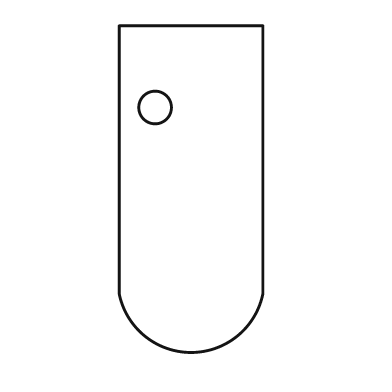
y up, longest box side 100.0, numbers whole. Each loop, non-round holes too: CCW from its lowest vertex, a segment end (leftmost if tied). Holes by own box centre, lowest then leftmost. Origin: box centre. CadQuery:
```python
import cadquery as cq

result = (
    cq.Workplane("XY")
    .moveTo(-22.0, -32.0)
    .threePointArc((0.0, -50.0), (22.0, -32.0))
    .lineTo(22.0, 50.0)
    .lineTo(-22.0, 50.0)
    .close()
    .moveTo(-11.0, 25.0)
    .circle(5.0)
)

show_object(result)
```